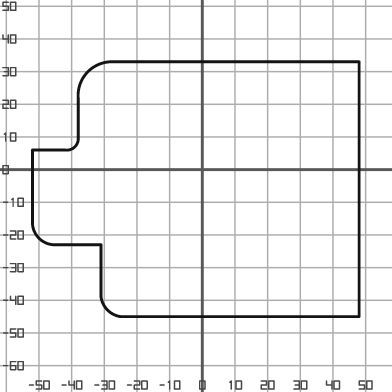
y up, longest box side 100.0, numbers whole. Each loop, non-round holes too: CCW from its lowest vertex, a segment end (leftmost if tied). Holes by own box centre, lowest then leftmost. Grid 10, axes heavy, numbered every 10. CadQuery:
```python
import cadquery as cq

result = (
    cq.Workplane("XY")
    .moveTo(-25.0, -45.0)
    .lineTo(48.0, -45.0)
    .lineTo(48.0, 33.0)
    .lineTo(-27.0, 33.0)
    .threePointArc((-35.0, 30.0), (-38.0, 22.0))
    .lineTo(-38.0, 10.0)
    .threePointArc((-39.0, 7.0), (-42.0, 6.0))
    .lineTo(-52.0, 6.0)
    .lineTo(-52.0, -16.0)
    .threePointArc((-50.0, -21.0), (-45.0, -23.0))
    .lineTo(-31.0, -23.0)
    .lineTo(-31.0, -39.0)
    .threePointArc((-29.0, -43.0), (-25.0, -45.0))
    .close()
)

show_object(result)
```